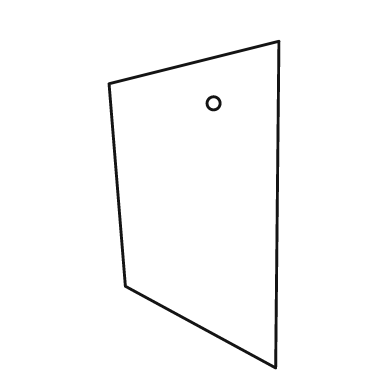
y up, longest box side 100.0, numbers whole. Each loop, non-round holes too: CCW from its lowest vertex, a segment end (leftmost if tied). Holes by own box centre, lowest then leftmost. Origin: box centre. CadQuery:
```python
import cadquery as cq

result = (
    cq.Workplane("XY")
    .moveTo(25.0, -50.0)
    .lineTo(26.0, 50.0)
    .lineTo(-26.0, 37.0)
    .lineTo(-21.0, -25.0)
    .close()
    .moveTo(6.0, 31.0)
    .circle(2.0)
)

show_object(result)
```